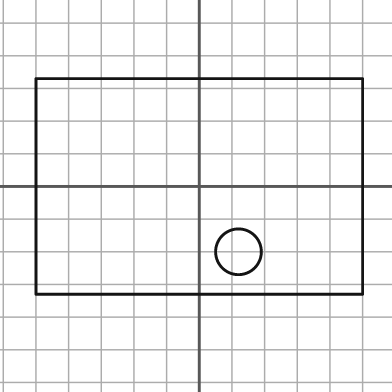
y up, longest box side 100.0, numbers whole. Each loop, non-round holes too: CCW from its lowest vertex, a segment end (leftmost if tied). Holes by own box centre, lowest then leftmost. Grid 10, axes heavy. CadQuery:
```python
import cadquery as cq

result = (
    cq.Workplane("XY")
    .moveTo(-50.0, -33.0)
    .lineTo(50.0, -33.0)
    .lineTo(50.0, 33.0)
    .lineTo(-50.0, 33.0)
    .close()
    .moveTo(12.0, -20.0)
    .circle(7.0)
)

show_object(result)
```